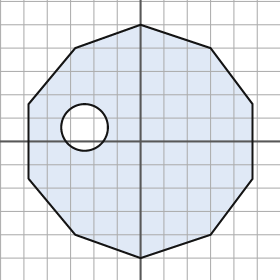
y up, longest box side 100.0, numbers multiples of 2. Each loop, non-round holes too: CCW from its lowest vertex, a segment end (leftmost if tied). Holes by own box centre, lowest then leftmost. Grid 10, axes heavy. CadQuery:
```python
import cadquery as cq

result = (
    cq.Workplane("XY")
    .moveTo(0.0, -50.0)
    .lineTo(30.0, -40.0)
    .lineTo(48.0, -16.0)
    .lineTo(48.0, 16.0)
    .lineTo(30.0, 40.0)
    .lineTo(0.0, 50.0)
    .lineTo(-28.0, 40.0)
    .lineTo(-48.0, 16.0)
    .lineTo(-48.0, -16.0)
    .lineTo(-28.0, -40.0)
    .close()
    .moveTo(-24.0, 6.0)
    .circle(10.0)
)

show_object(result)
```